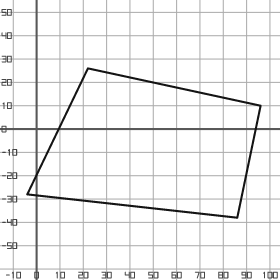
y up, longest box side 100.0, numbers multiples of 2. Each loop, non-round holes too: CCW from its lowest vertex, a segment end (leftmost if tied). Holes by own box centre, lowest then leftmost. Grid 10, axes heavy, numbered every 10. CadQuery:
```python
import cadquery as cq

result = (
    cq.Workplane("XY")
    .moveTo(86.0, -38.0)
    .lineTo(96.0, 10.0)
    .lineTo(22.0, 26.0)
    .lineTo(-4.0, -28.0)
    .close()
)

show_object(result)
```